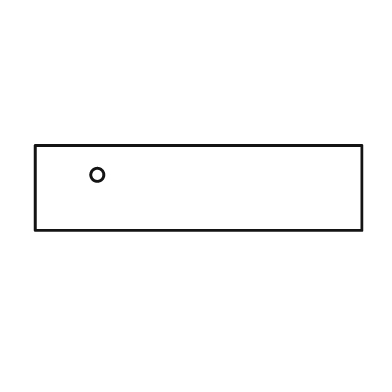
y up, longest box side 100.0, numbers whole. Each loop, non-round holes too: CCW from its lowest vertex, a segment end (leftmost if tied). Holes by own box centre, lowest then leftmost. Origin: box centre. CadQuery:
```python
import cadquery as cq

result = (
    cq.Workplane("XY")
    .moveTo(-50.0, -13.0)
    .lineTo(50.0, -13.0)
    .lineTo(50.0, 13.0)
    .lineTo(-50.0, 13.0)
    .close()
    .moveTo(-31.0, 4.0)
    .circle(2.0)
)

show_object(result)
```